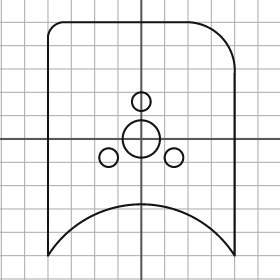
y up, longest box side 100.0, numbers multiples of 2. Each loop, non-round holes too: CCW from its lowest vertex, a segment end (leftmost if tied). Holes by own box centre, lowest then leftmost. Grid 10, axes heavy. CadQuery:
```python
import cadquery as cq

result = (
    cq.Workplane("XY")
    .moveTo(-40.0, -50.0)
    .threePointArc((0.0, -28.0), (40.0, -50.0))
    .lineTo(40.0, 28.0)
    .threePointArc((34.0, 44.0), (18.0, 50.0))
    .lineTo(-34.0, 50.0)
    .threePointArc((-38.0, 48.0), (-40.0, 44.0))
    .close()
    .moveTo(-14.0, -8.0)
    .circle(4.0)
    .moveTo(14.0, -8.0)
    .circle(4.0)
    .moveTo(0.0, 0.0)
    .circle(8.0)
    .moveTo(0.0, 16.0)
    .circle(4.0)
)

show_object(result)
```